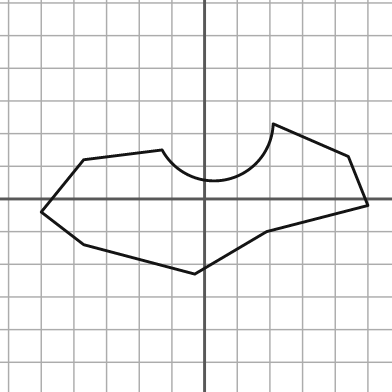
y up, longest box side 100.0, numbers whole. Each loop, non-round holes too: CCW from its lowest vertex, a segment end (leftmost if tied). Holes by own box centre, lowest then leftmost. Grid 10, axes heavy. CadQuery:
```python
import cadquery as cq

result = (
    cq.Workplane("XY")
    .moveTo(-3.0, -23.0)
    .lineTo(19.0, -10.0)
    .lineTo(50.0, -2.0)
    .lineTo(44.0, 13.0)
    .lineTo(21.0, 23.0)
    .threePointArc((7.0, 6.0), (-13.0, 15.0))
    .lineTo(-37.0, 12.0)
    .lineTo(-50.0, -4.0)
    .lineTo(-37.0, -14.0)
    .close()
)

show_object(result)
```